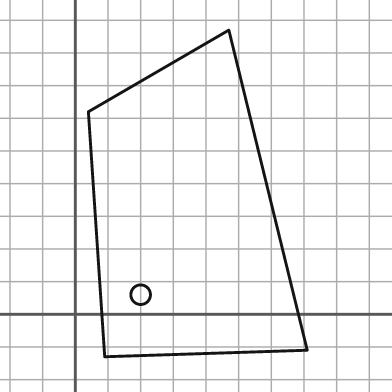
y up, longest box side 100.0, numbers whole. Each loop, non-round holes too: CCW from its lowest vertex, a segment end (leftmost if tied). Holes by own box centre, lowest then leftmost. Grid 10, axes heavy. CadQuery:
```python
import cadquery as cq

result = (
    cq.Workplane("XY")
    .moveTo(9.0, -13.0)
    .lineTo(71.0, -11.0)
    .lineTo(47.0, 87.0)
    .lineTo(4.0, 62.0)
    .close()
    .moveTo(20.0, 6.0)
    .circle(3.0)
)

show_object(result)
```